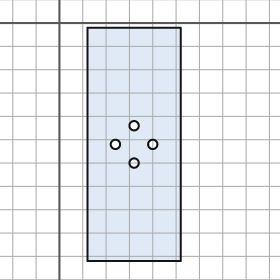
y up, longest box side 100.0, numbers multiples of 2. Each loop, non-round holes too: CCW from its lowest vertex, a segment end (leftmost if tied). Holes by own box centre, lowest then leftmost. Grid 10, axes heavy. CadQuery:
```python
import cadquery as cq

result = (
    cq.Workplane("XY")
    .moveTo(12.0, -102.0)
    .lineTo(52.0, -102.0)
    .lineTo(52.0, -2.0)
    .lineTo(12.0, -2.0)
    .close()
    .moveTo(32.0, -60.0)
    .circle(2.0)
    .moveTo(24.0, -52.0)
    .circle(2.0)
    .moveTo(40.0, -52.0)
    .circle(2.0)
    .moveTo(32.0, -44.0)
    .circle(2.0)
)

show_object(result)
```